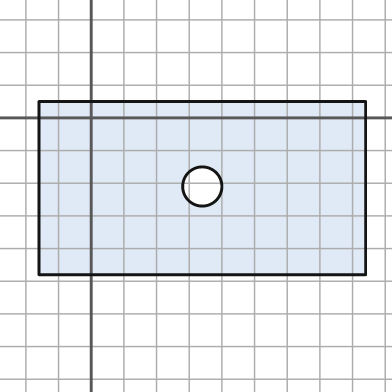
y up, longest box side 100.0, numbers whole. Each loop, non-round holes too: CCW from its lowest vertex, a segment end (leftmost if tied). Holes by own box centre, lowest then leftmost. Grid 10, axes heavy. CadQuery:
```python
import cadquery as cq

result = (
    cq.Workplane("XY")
    .moveTo(-16.0, -48.0)
    .lineTo(84.0, -48.0)
    .lineTo(84.0, 5.0)
    .lineTo(-16.0, 5.0)
    .close()
    .moveTo(34.0, -21.0)
    .circle(6.0)
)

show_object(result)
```